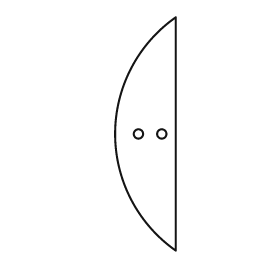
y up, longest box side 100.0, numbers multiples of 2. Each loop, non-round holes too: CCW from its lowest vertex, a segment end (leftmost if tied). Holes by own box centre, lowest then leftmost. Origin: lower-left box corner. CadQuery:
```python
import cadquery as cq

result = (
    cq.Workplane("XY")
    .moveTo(26.0, 0.0)
    .lineTo(26.0, 100.0)
    .threePointArc((0.0, 50.0), (26.0, 0.0))
    .close()
    .moveTo(10.0, 50.0)
    .circle(2.0)
    .moveTo(20.0, 50.0)
    .circle(2.0)
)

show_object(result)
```